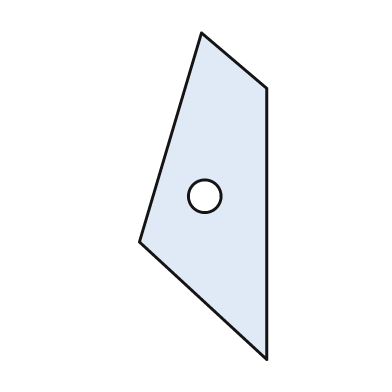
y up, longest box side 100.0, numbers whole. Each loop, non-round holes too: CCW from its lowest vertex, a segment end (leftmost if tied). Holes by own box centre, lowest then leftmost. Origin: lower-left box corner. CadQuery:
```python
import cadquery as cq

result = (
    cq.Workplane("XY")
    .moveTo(39.0, 0.0)
    .lineTo(39.0, 83.0)
    .lineTo(19.0, 100.0)
    .lineTo(0.0, 36.0)
    .close()
    .moveTo(20.0, 50.0)
    .circle(5.0)
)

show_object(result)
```